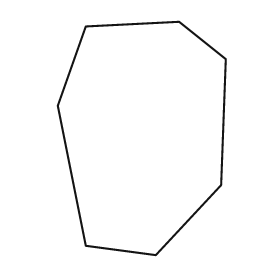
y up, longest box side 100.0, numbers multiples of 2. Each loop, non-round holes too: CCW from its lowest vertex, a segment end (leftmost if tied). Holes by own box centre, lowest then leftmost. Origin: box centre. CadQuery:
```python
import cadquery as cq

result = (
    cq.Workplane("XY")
    .moveTo(6.0, -50.0)
    .lineTo(34.0, -20.0)
    .lineTo(36.0, 34.0)
    .lineTo(16.0, 50.0)
    .lineTo(-24.0, 48.0)
    .lineTo(-36.0, 14.0)
    .lineTo(-24.0, -46.0)
    .close()
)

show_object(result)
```